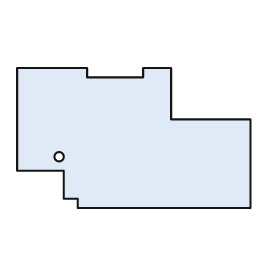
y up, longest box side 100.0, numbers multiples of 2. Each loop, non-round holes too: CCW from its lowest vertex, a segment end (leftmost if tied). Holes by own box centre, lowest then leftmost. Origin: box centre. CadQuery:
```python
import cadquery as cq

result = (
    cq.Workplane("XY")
    .moveTo(-24.0, -30.0)
    .lineTo(50.0, -30.0)
    .lineTo(50.0, 8.0)
    .lineTo(16.0, 8.0)
    .lineTo(16.0, 30.0)
    .lineTo(4.0, 30.0)
    .lineTo(4.0, 26.0)
    .lineTo(-20.0, 26.0)
    .lineTo(-20.0, 30.0)
    .lineTo(-50.0, 30.0)
    .lineTo(-50.0, -14.0)
    .lineTo(-30.0, -14.0)
    .lineTo(-30.0, -26.0)
    .lineTo(-24.0, -26.0)
    .close()
    .moveTo(-32.0, -8.0)
    .circle(2.0)
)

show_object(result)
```